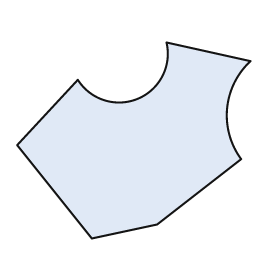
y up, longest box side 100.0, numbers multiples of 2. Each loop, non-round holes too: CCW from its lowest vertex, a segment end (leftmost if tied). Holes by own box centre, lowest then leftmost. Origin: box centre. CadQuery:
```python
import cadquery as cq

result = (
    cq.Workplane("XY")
    .moveTo(-18.0, -42.0)
    .lineTo(10.0, -36.0)
    .lineTo(46.0, -8.0)
    .threePointArc((40.0, 14.0), (50.0, 34.0))
    .lineTo(14.0, 42.0)
    .threePointArc((2.0, 18.0), (-24.0, 26.0))
    .lineTo(-50.0, -2.0)
    .close()
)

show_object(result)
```